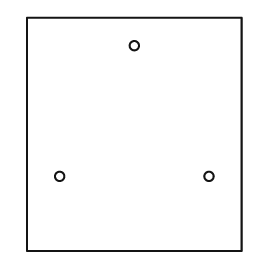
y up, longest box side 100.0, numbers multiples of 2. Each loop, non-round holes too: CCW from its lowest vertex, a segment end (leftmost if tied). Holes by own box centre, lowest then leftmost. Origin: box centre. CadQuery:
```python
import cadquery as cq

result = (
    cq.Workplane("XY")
    .moveTo(-46.0, -50.0)
    .lineTo(46.0, -50.0)
    .lineTo(46.0, 50.0)
    .lineTo(-46.0, 50.0)
    .close()
    .moveTo(-32.0, -18.0)
    .circle(2.0)
    .moveTo(32.0, -18.0)
    .circle(2.0)
    .moveTo(0.0, 38.0)
    .circle(2.0)
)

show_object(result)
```